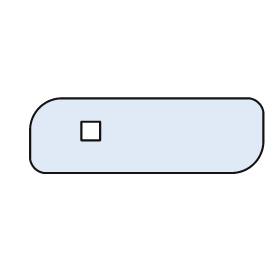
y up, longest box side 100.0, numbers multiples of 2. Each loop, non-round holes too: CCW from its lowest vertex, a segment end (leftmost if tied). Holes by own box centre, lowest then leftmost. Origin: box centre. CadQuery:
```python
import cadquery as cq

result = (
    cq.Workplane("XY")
    .moveTo(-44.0, -16.0)
    .lineTo(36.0, -16.0)
    .threePointArc((46.0, -12.0), (50.0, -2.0))
    .lineTo(50.0, 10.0)
    .threePointArc((48.0, 14.0), (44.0, 16.0))
    .lineTo(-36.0, 16.0)
    .threePointArc((-46.0, 12.0), (-50.0, 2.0))
    .lineTo(-50.0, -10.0)
    .threePointArc((-48.0, -14.0), (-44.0, -16.0))
    .close()
    .moveTo(-28.0, -2.0)
    .lineTo(-20.0, -2.0)
    .lineTo(-20.0, 6.0)
    .lineTo(-28.0, 6.0)
    .close()
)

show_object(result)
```